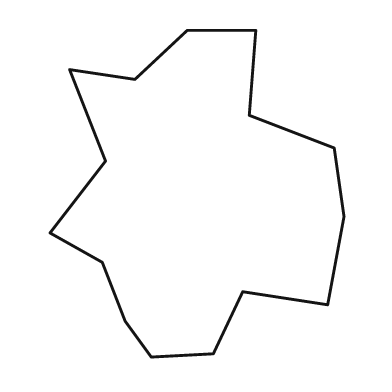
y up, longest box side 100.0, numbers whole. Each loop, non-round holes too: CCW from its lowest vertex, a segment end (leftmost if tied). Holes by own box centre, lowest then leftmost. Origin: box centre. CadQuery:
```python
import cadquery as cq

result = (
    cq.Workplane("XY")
    .moveTo(-14.0, -50.0)
    .lineTo(5.0, -49.0)
    .lineTo(14.0, -30.0)
    .lineTo(40.0, -34.0)
    .lineTo(45.0, -7.0)
    .lineTo(42.0, 14.0)
    .lineTo(16.0, 24.0)
    .lineTo(18.0, 50.0)
    .lineTo(-3.0, 50.0)
    .lineTo(-19.0, 35.0)
    .lineTo(-39.0, 38.0)
    .lineTo(-28.0, 10.0)
    .lineTo(-45.0, -12.0)
    .lineTo(-29.0, -21.0)
    .lineTo(-22.0, -39.0)
    .close()
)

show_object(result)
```